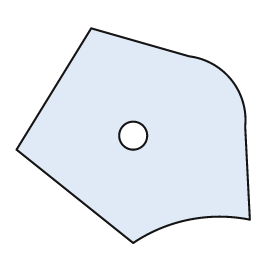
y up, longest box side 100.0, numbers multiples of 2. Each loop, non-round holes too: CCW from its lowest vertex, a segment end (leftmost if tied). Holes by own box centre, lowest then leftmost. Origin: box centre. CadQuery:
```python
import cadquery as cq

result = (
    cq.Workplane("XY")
    .moveTo(0.0, -46.0)
    .threePointArc((24.0, -36.0), (50.0, -36.0))
    .lineTo(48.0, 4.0)
    .threePointArc((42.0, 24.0), (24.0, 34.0))
    .lineTo(-18.0, 46.0)
    .lineTo(-50.0, -6.0)
    .close()
    .moveTo(0.0, 0.0)
    .circle(6.0)
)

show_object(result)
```